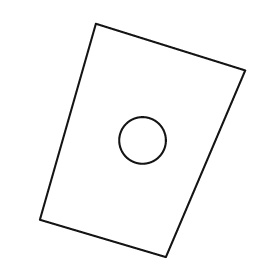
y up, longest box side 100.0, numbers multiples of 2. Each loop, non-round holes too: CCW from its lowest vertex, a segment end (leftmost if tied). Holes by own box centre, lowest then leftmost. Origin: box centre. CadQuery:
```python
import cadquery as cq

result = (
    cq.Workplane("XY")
    .moveTo(10.0, -50.0)
    .lineTo(44.0, 30.0)
    .lineTo(-20.0, 50.0)
    .lineTo(-44.0, -34.0)
    .close()
    .moveTo(0.0, 0.0)
    .circle(10.0)
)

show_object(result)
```